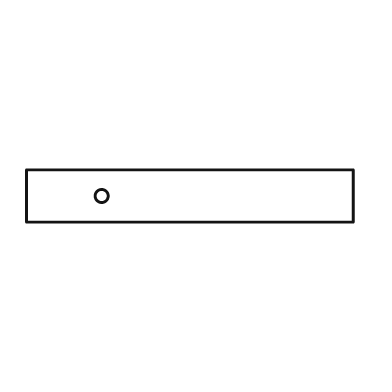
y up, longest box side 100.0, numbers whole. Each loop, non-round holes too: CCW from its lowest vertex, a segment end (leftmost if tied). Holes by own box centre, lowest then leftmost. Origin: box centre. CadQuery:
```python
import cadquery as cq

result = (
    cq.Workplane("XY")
    .moveTo(-50.0, -8.0)
    .lineTo(50.0, -8.0)
    .lineTo(50.0, 8.0)
    .lineTo(-50.0, 8.0)
    .close()
    .moveTo(-27.0, 0.0)
    .circle(2.0)
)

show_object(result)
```